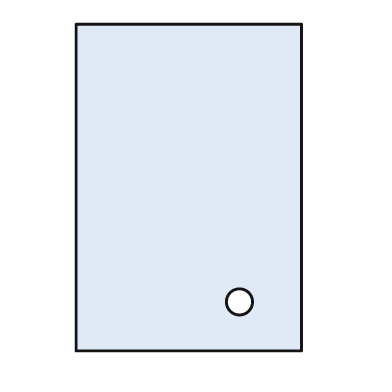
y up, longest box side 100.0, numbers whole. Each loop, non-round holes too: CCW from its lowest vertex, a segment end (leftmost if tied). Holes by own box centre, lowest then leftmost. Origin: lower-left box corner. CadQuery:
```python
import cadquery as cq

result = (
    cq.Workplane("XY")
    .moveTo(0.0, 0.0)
    .lineTo(69.0, 0.0)
    .lineTo(69.0, 100.0)
    .lineTo(0.0, 100.0)
    .close()
    .moveTo(50.0, 15.0)
    .circle(4.0)
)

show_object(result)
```